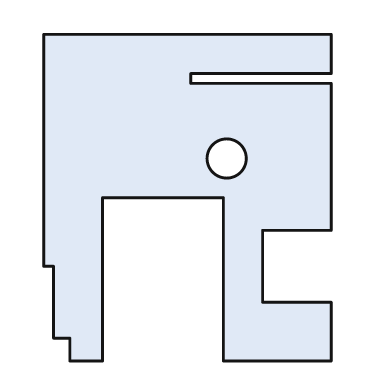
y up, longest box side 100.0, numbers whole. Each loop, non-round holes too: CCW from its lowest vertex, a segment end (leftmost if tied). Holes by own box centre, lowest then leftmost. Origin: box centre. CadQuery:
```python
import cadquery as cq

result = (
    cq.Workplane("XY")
    .moveTo(-36.0, -50.0)
    .lineTo(-26.0, -50.0)
    .lineTo(-26.0, 0.0)
    .lineTo(11.0, 0.0)
    .lineTo(11.0, -50.0)
    .lineTo(44.0, -50.0)
    .lineTo(44.0, -32.0)
    .lineTo(23.0, -32.0)
    .lineTo(23.0, -10.0)
    .lineTo(44.0, -10.0)
    .lineTo(44.0, 35.0)
    .lineTo(1.0, 35.0)
    .lineTo(1.0, 38.0)
    .lineTo(44.0, 38.0)
    .lineTo(44.0, 50.0)
    .lineTo(-44.0, 50.0)
    .lineTo(-44.0, -21.0)
    .lineTo(-41.0, -21.0)
    .lineTo(-41.0, -43.0)
    .lineTo(-36.0, -43.0)
    .close()
    .moveTo(12.0, 12.0)
    .circle(6.0)
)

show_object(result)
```